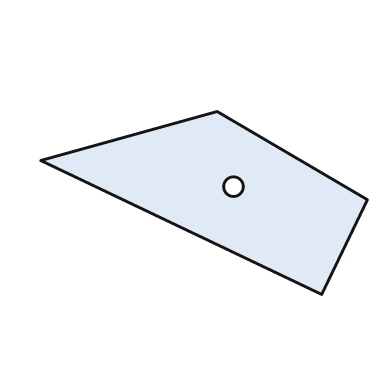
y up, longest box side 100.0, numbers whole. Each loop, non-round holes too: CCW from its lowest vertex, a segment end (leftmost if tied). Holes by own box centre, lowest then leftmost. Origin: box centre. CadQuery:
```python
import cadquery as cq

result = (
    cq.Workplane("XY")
    .moveTo(36.0, -28.0)
    .lineTo(50.0, 1.0)
    .lineTo(4.0, 28.0)
    .lineTo(-50.0, 13.0)
    .close()
    .moveTo(9.0, 5.0)
    .circle(3.0)
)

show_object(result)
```